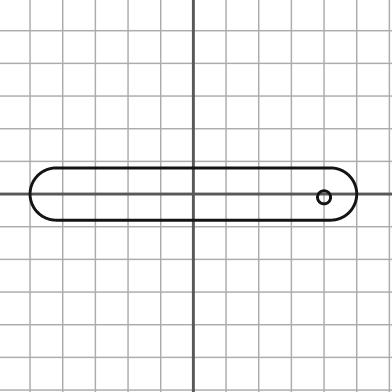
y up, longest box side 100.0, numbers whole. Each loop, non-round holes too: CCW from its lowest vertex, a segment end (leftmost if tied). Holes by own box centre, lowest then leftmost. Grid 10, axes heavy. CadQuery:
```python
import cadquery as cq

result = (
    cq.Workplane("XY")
    .moveTo(-42.0, -8.0)
    .lineTo(42.0, -8.0)
    .threePointArc((50.0, 0.0), (42.0, 8.0))
    .lineTo(-42.0, 8.0)
    .threePointArc((-50.0, 0.0), (-42.0, -8.0))
    .close()
    .moveTo(40.0, -1.0)
    .circle(2.0)
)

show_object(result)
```